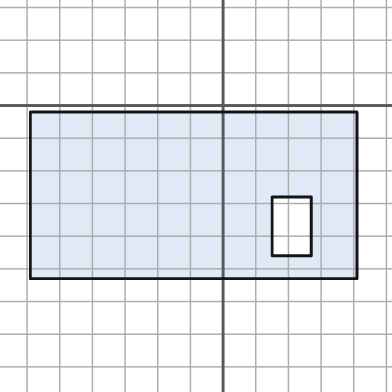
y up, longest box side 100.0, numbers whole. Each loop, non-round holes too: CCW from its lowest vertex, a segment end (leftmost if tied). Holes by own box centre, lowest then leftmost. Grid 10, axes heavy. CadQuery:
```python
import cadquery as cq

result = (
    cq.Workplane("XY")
    .moveTo(-59.0, -53.0)
    .lineTo(41.0, -53.0)
    .lineTo(41.0, -2.0)
    .lineTo(-59.0, -2.0)
    .close()
    .moveTo(15.0, -46.0)
    .lineTo(27.0, -46.0)
    .lineTo(27.0, -28.0)
    .lineTo(15.0, -28.0)
    .close()
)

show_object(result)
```